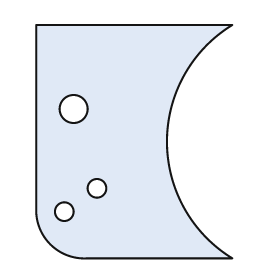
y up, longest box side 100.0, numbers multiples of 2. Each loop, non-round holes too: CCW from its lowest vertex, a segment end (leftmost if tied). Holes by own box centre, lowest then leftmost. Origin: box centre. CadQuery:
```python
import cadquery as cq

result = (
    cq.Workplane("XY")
    .moveTo(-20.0, -50.0)
    .lineTo(42.0, -50.0)
    .threePointArc((14.0, 0.0), (42.0, 50.0))
    .lineTo(-42.0, 50.0)
    .lineTo(-42.0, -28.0)
    .threePointArc((-36.0, -44.0), (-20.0, -50.0))
    .close()
    .moveTo(-30.0, -30.0)
    .circle(4.0)
    .moveTo(-16.0, -20.0)
    .circle(4.0)
    .moveTo(-26.0, 14.0)
    .circle(6.0)
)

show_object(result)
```